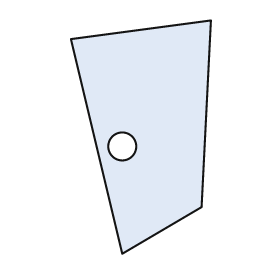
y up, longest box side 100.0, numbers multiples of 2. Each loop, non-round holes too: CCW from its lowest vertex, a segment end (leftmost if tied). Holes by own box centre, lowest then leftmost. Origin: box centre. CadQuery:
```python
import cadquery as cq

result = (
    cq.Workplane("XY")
    .moveTo(-8.0, -50.0)
    .lineTo(26.0, -30.0)
    .lineTo(30.0, 50.0)
    .lineTo(-30.0, 42.0)
    .close()
    .moveTo(-8.0, -4.0)
    .circle(6.0)
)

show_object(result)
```